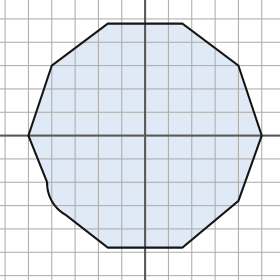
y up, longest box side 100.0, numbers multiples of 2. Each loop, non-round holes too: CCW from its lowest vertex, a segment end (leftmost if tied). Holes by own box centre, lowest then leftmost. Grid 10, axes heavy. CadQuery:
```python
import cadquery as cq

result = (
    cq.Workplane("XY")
    .moveTo(-16.0, -48.0)
    .lineTo(16.0, -48.0)
    .lineTo(40.0, -28.0)
    .lineTo(50.0, 0.0)
    .lineTo(40.0, 30.0)
    .lineTo(16.0, 48.0)
    .lineTo(-16.0, 48.0)
    .lineTo(-40.0, 30.0)
    .lineTo(-50.0, 0.0)
    .lineTo(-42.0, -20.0)
    .threePointArc((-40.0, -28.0), (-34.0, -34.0))
    .close()
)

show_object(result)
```